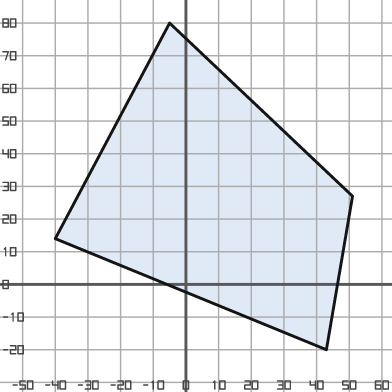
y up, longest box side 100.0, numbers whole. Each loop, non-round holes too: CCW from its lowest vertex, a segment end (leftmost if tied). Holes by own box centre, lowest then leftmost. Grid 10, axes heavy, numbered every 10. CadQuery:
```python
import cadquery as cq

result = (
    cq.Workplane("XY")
    .moveTo(43.0, -20.0)
    .lineTo(51.0, 27.0)
    .lineTo(-5.0, 80.0)
    .lineTo(-40.0, 14.0)
    .close()
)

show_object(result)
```